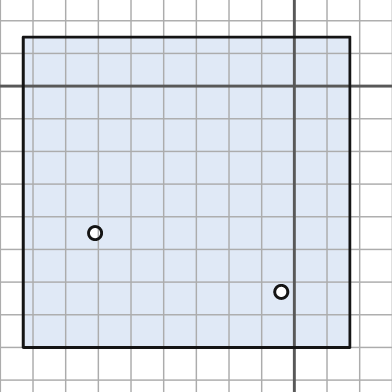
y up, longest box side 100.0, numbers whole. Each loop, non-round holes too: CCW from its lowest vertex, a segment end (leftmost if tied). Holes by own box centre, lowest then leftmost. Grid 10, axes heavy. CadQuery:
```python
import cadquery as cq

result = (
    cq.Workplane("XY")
    .moveTo(-83.0, -80.0)
    .lineTo(17.0, -80.0)
    .lineTo(17.0, 15.0)
    .lineTo(-83.0, 15.0)
    .close()
    .moveTo(-4.0, -63.0)
    .circle(2.0)
    .moveTo(-61.0, -45.0)
    .circle(2.0)
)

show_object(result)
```